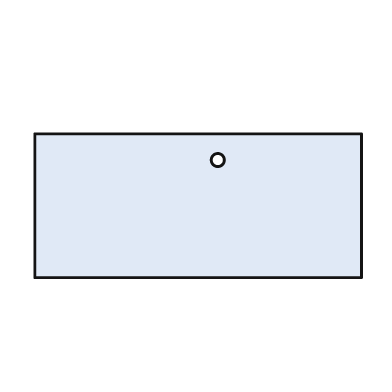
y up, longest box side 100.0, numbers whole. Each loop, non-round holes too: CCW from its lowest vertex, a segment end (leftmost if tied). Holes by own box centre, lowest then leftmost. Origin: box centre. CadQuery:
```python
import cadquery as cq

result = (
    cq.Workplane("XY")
    .moveTo(-50.0, -22.0)
    .lineTo(50.0, -22.0)
    .lineTo(50.0, 22.0)
    .lineTo(-50.0, 22.0)
    .close()
    .moveTo(6.0, 14.0)
    .circle(2.0)
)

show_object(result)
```